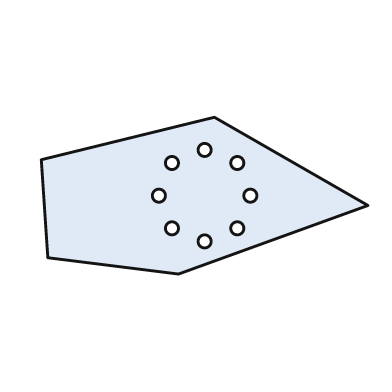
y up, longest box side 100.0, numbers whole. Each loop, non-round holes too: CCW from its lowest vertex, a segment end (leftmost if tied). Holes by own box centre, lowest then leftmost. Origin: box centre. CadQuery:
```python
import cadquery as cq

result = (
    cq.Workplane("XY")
    .moveTo(-8.0, -24.0)
    .lineTo(50.0, -3.0)
    .lineTo(3.0, 24.0)
    .lineTo(-50.0, 11.0)
    .lineTo(-48.0, -19.0)
    .close()
    .moveTo(0.0, -14.0)
    .circle(2.0)
    .moveTo(-10.0, -10.0)
    .circle(2.0)
    .moveTo(10.0, -10.0)
    .circle(2.0)
    .moveTo(-14.0, 0.0)
    .circle(2.0)
    .moveTo(14.0, 0.0)
    .circle(2.0)
    .moveTo(-10.0, 10.0)
    .circle(2.0)
    .moveTo(10.0, 10.0)
    .circle(2.0)
    .moveTo(0.0, 14.0)
    .circle(2.0)
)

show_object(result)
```